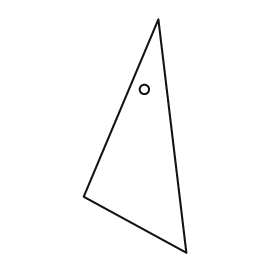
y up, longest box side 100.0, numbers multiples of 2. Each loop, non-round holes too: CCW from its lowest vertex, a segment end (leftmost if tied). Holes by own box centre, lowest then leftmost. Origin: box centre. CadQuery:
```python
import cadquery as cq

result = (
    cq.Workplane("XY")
    .moveTo(22.0, -50.0)
    .lineTo(10.0, 50.0)
    .lineTo(-22.0, -26.0)
    .close()
    .moveTo(4.0, 20.0)
    .circle(2.0)
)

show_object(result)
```